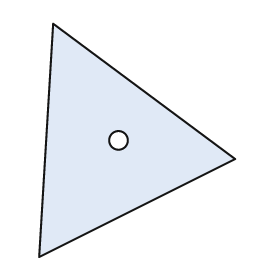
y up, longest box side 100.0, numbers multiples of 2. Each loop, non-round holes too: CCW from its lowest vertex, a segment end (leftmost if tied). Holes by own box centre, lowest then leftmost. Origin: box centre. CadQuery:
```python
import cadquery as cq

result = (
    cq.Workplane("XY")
    .moveTo(-42.0, -50.0)
    .lineTo(42.0, -8.0)
    .lineTo(-36.0, 50.0)
    .close()
    .moveTo(-8.0, 0.0)
    .circle(4.0)
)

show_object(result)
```